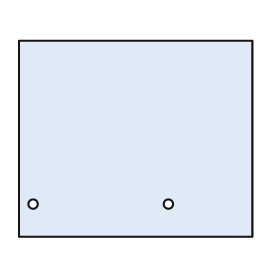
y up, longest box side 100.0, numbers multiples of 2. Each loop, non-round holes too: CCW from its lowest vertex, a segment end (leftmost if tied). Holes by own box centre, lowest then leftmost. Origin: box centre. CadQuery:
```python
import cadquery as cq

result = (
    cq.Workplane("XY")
    .moveTo(-50.0, -42.0)
    .lineTo(50.0, -42.0)
    .lineTo(50.0, 42.0)
    .lineTo(-50.0, 42.0)
    .close()
    .moveTo(-44.0, -28.0)
    .circle(2.0)
    .moveTo(14.0, -28.0)
    .circle(2.0)
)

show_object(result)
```